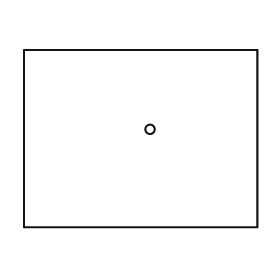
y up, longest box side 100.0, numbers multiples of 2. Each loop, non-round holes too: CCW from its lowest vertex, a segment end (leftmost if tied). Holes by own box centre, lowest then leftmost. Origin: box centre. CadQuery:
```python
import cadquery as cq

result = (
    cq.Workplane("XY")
    .moveTo(-50.0, -38.0)
    .lineTo(50.0, -38.0)
    .lineTo(50.0, 38.0)
    .lineTo(-50.0, 38.0)
    .close()
    .moveTo(4.0, 4.0)
    .circle(2.0)
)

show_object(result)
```